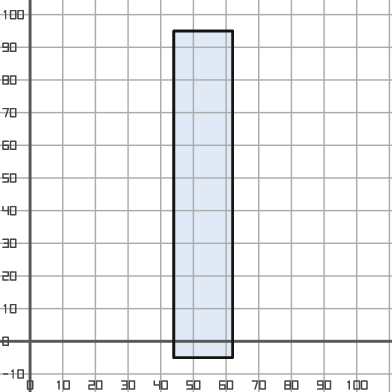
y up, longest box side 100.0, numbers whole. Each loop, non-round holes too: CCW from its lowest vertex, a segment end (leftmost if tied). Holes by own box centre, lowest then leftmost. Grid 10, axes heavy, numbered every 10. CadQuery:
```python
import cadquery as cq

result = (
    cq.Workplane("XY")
    .moveTo(44.0, -5.0)
    .lineTo(62.0, -5.0)
    .lineTo(62.0, 95.0)
    .lineTo(44.0, 95.0)
    .close()
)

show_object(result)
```